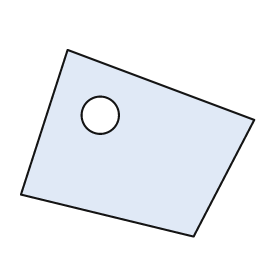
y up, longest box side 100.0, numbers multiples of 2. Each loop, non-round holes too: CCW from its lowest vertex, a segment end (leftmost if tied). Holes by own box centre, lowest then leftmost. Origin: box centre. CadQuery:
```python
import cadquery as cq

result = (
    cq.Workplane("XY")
    .moveTo(24.0, -40.0)
    .lineTo(50.0, 10.0)
    .lineTo(-30.0, 40.0)
    .lineTo(-50.0, -22.0)
    .close()
    .moveTo(-16.0, 12.0)
    .circle(8.0)
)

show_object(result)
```